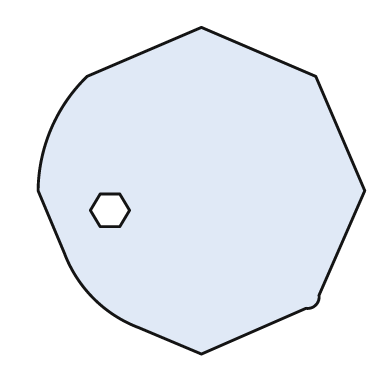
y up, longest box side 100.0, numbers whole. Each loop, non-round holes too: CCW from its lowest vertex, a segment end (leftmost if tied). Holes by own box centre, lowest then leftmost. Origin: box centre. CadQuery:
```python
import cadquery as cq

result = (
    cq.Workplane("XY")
    .moveTo(0.0, -50.0)
    .lineTo(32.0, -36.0)
    .threePointArc((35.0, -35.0), (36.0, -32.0))
    .lineTo(50.0, 0.0)
    .lineTo(35.0, 35.0)
    .lineTo(0.0, 50.0)
    .lineTo(-35.0, 35.0)
    .threePointArc((-46.0, 19.0), (-50.0, 0.0))
    .lineTo(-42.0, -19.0)
    .threePointArc((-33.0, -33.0), (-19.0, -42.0))
    .close()
    .moveTo(-31.0, -11.0)
    .lineTo(-25.0, -11.0)
    .lineTo(-22.0, -6.0)
    .lineTo(-25.0, -1.0)
    .lineTo(-31.0, -1.0)
    .lineTo(-34.0, -6.0)
    .close()
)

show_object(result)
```